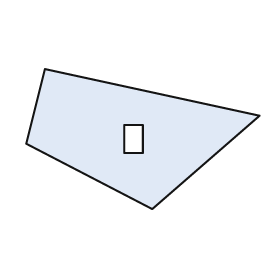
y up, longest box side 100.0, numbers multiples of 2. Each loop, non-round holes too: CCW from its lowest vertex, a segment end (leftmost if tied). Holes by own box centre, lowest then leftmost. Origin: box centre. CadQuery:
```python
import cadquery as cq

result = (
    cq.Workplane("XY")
    .moveTo(4.0, -30.0)
    .lineTo(50.0, 10.0)
    .lineTo(-42.0, 30.0)
    .lineTo(-50.0, -2.0)
    .close()
    .moveTo(-8.0, -6.0)
    .lineTo(0.0, -6.0)
    .lineTo(0.0, 6.0)
    .lineTo(-8.0, 6.0)
    .close()
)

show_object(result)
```